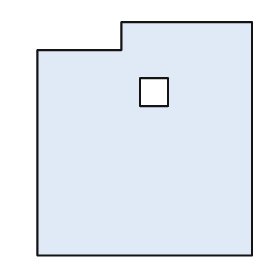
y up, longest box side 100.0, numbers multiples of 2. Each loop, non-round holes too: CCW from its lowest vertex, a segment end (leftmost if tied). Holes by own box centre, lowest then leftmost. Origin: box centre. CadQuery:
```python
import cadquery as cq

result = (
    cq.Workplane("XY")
    .moveTo(-46.0, -50.0)
    .lineTo(46.0, -50.0)
    .lineTo(46.0, 50.0)
    .lineTo(-10.0, 50.0)
    .lineTo(-10.0, 38.0)
    .lineTo(-46.0, 38.0)
    .close()
    .moveTo(-2.0, 14.0)
    .lineTo(10.0, 14.0)
    .lineTo(10.0, 26.0)
    .lineTo(-2.0, 26.0)
    .close()
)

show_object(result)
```